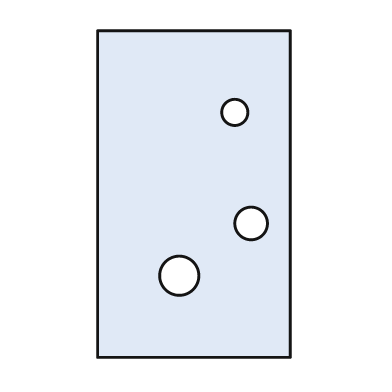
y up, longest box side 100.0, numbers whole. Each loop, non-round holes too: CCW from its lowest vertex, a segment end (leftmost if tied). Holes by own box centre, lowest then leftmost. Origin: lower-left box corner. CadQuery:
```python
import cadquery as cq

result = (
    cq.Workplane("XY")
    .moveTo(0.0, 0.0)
    .lineTo(59.0, 0.0)
    .lineTo(59.0, 100.0)
    .lineTo(0.0, 100.0)
    .close()
    .moveTo(25.0, 25.0)
    .circle(6.0)
    .moveTo(47.0, 41.0)
    .circle(5.0)
    .moveTo(42.0, 75.0)
    .circle(4.0)
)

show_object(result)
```